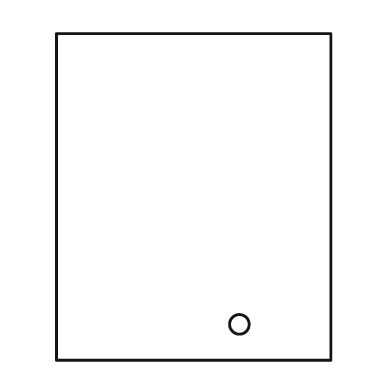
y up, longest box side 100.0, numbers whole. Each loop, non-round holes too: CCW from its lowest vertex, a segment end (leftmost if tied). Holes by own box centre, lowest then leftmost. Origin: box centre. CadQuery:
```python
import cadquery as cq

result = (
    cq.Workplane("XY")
    .moveTo(-42.0, -50.0)
    .lineTo(42.0, -50.0)
    .lineTo(42.0, 50.0)
    .lineTo(-42.0, 50.0)
    .close()
    .moveTo(14.0, -39.0)
    .circle(3.0)
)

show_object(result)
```